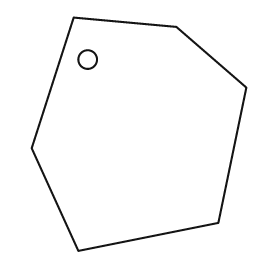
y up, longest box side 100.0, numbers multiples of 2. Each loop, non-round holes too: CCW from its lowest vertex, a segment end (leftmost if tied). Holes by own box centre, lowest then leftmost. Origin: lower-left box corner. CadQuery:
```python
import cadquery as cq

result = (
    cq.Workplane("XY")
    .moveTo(20.0, 0.0)
    .lineTo(80.0, 12.0)
    .lineTo(92.0, 70.0)
    .lineTo(62.0, 96.0)
    .lineTo(18.0, 100.0)
    .lineTo(0.0, 44.0)
    .close()
    .moveTo(24.0, 82.0)
    .circle(4.0)
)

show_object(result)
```